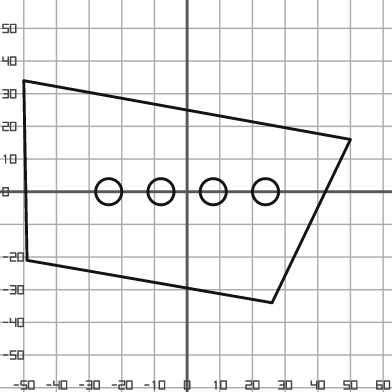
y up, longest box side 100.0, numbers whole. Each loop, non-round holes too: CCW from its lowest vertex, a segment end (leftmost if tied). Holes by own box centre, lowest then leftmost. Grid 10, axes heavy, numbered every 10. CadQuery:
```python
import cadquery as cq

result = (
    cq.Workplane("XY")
    .moveTo(26.0, -34.0)
    .lineTo(50.0, 16.0)
    .lineTo(-50.0, 34.0)
    .lineTo(-49.0, -21.0)
    .close()
    .moveTo(-24.0, 0.0)
    .circle(4.0)
    .moveTo(-8.0, 0.0)
    .circle(4.0)
    .moveTo(8.0, 0.0)
    .circle(4.0)
    .moveTo(24.0, 0.0)
    .circle(4.0)
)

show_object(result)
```